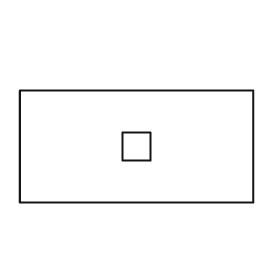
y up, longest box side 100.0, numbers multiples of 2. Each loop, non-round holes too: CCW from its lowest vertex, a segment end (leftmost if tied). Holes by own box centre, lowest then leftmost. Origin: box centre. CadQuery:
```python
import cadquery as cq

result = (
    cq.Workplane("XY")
    .moveTo(-50.0, -24.0)
    .lineTo(50.0, -24.0)
    .lineTo(50.0, 24.0)
    .lineTo(-50.0, 24.0)
    .close()
    .moveTo(-6.0, -6.0)
    .lineTo(6.0, -6.0)
    .lineTo(6.0, 6.0)
    .lineTo(-6.0, 6.0)
    .close()
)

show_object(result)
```